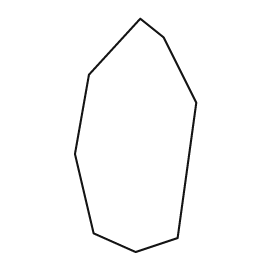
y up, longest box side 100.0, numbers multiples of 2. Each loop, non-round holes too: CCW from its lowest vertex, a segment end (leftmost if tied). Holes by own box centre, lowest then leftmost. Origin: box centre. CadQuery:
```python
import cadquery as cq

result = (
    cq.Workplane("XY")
    .moveTo(0.0, -50.0)
    .lineTo(18.0, -44.0)
    .lineTo(26.0, 14.0)
    .lineTo(12.0, 42.0)
    .lineTo(2.0, 50.0)
    .lineTo(-20.0, 26.0)
    .lineTo(-26.0, -8.0)
    .lineTo(-18.0, -42.0)
    .close()
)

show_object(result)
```